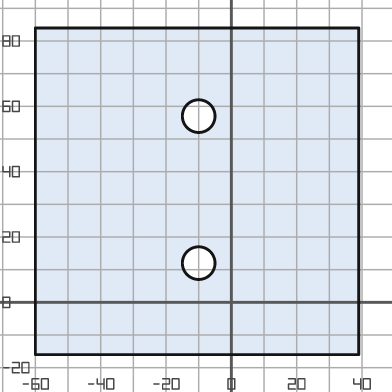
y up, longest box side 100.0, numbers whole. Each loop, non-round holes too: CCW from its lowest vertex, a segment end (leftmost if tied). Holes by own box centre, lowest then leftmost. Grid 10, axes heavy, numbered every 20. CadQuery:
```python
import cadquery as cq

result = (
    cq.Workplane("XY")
    .moveTo(-60.0, -16.0)
    .lineTo(39.0, -16.0)
    .lineTo(39.0, 84.0)
    .lineTo(-60.0, 84.0)
    .close()
    .moveTo(-10.0, 12.0)
    .circle(5.0)
    .moveTo(-10.0, 57.0)
    .circle(5.0)
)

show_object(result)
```